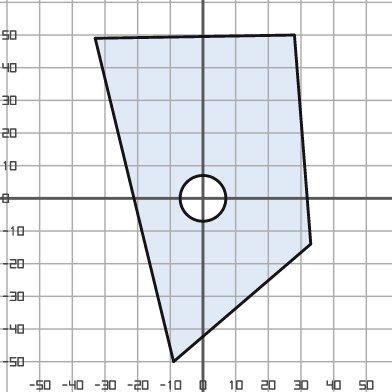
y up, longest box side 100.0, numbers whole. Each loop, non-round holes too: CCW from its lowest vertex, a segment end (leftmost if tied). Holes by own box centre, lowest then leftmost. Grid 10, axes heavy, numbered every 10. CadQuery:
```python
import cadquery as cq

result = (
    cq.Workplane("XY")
    .moveTo(-9.0, -50.0)
    .lineTo(33.0, -14.0)
    .lineTo(28.0, 50.0)
    .lineTo(-33.0, 49.0)
    .close()
    .moveTo(0.0, 0.0)
    .circle(7.0)
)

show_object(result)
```